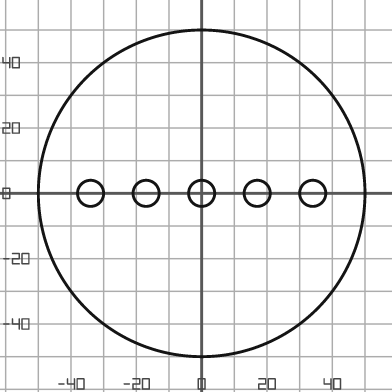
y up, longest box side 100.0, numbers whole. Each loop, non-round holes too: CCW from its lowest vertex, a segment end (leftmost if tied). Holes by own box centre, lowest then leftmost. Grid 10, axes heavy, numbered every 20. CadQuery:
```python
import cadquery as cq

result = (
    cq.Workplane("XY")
    .moveTo(0.0, 0.0)
    .circle(50.0)
    .moveTo(-34.0, 0.0)
    .circle(4.0)
    .moveTo(-17.0, 0.0)
    .circle(4.0)
    .moveTo(0.0, 0.0)
    .circle(4.0)
    .moveTo(17.0, 0.0)
    .circle(4.0)
    .moveTo(34.0, 0.0)
    .circle(4.0)
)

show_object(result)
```